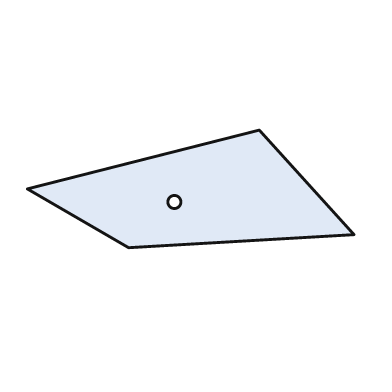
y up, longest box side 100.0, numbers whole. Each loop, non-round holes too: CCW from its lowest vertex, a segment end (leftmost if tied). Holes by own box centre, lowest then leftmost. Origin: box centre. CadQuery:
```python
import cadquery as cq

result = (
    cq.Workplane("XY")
    .moveTo(-19.0, -18.0)
    .lineTo(50.0, -14.0)
    .lineTo(21.0, 18.0)
    .lineTo(-50.0, 0.0)
    .close()
    .moveTo(-5.0, -4.0)
    .circle(2.0)
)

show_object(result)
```